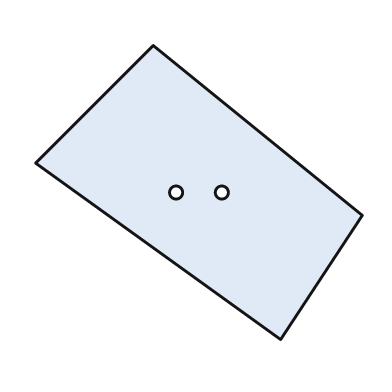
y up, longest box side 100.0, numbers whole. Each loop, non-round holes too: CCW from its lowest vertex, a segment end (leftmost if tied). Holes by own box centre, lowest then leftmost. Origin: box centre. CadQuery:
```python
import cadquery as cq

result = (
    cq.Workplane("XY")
    .moveTo(25.0, -45.0)
    .lineTo(50.0, -7.0)
    .lineTo(-14.0, 45.0)
    .lineTo(-50.0, 9.0)
    .close()
    .moveTo(-7.0, 0.0)
    .circle(2.0)
    .moveTo(7.0, 0.0)
    .circle(2.0)
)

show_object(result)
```